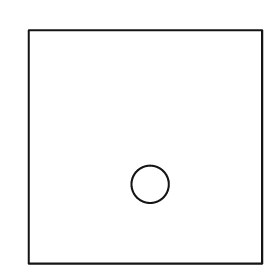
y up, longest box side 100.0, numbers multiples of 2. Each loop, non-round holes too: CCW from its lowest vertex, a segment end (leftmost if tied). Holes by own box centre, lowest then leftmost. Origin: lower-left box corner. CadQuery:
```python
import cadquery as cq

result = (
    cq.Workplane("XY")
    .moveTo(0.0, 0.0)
    .lineTo(100.0, 0.0)
    .lineTo(100.0, 100.0)
    .lineTo(0.0, 100.0)
    .close()
    .moveTo(52.0, 34.0)
    .circle(8.0)
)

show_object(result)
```